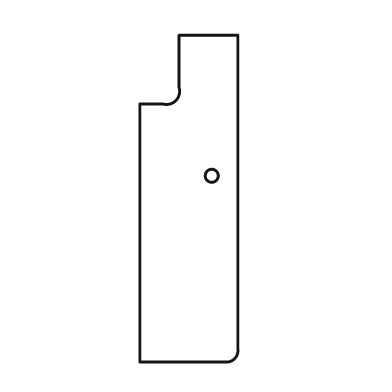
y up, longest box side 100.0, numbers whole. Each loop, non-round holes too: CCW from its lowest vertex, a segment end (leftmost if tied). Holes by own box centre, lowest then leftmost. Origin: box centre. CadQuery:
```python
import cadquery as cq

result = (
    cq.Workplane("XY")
    .moveTo(-15.0, -50.0)
    .lineTo(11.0, -50.0)
    .threePointArc((14.0, -49.0), (15.0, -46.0))
    .lineTo(15.0, 50.0)
    .lineTo(-3.0, 50.0)
    .lineTo(-3.0, 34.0)
    .threePointArc((-4.0, 30.0), (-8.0, 29.0))
    .lineTo(-15.0, 29.0)
    .close()
    .moveTo(7.0, 7.0)
    .circle(2.0)
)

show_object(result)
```